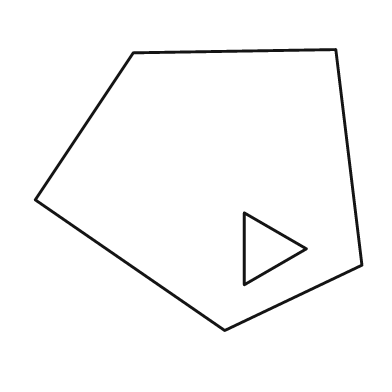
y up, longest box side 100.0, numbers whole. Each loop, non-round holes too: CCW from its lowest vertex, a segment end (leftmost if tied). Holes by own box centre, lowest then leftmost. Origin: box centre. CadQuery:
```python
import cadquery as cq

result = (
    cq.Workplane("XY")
    .moveTo(8.0, -43.0)
    .lineTo(50.0, -23.0)
    .lineTo(42.0, 43.0)
    .lineTo(-20.0, 42.0)
    .lineTo(-50.0, -3.0)
    .close()
    .moveTo(14.0, -29.0)
    .lineTo(33.0, -18.0)
    .lineTo(14.0, -7.0)
    .close()
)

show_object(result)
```